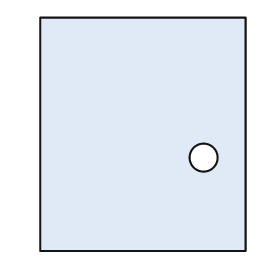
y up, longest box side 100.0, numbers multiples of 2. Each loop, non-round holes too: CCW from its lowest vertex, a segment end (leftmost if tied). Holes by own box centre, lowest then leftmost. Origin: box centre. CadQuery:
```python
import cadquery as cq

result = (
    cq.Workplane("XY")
    .moveTo(-44.0, -50.0)
    .lineTo(44.0, -50.0)
    .lineTo(44.0, 50.0)
    .lineTo(-44.0, 50.0)
    .close()
    .moveTo(26.0, -10.0)
    .circle(6.0)
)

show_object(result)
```